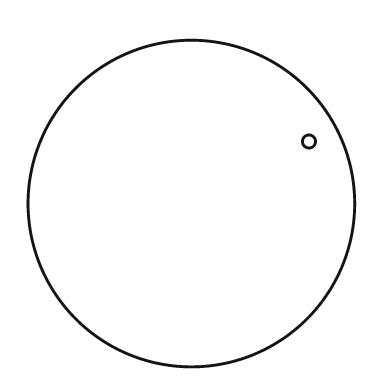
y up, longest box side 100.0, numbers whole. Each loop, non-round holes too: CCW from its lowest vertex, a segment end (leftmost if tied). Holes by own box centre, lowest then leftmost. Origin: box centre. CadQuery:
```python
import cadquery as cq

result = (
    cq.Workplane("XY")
    .moveTo(0.0, 0.0)
    .circle(50.0)
    .moveTo(36.0, 19.0)
    .circle(2.0)
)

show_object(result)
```